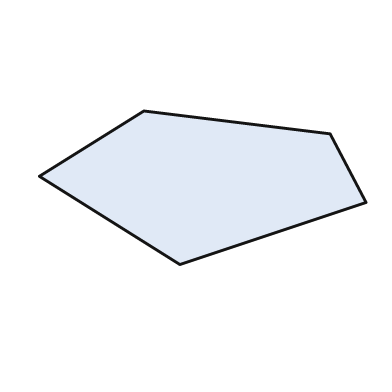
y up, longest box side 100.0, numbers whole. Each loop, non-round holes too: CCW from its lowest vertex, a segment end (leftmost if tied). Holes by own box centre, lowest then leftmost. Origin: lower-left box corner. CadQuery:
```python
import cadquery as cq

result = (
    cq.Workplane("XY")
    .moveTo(43.0, 0.0)
    .lineTo(100.0, 19.0)
    .lineTo(89.0, 40.0)
    .lineTo(32.0, 47.0)
    .lineTo(0.0, 27.0)
    .close()
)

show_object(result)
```